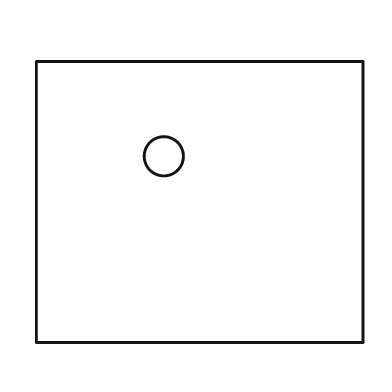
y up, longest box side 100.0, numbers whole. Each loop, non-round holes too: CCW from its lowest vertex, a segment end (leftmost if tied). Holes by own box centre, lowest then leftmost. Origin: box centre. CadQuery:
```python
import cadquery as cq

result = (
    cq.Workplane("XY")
    .moveTo(-50.0, -43.0)
    .lineTo(50.0, -43.0)
    .lineTo(50.0, 43.0)
    .lineTo(-50.0, 43.0)
    .close()
    .moveTo(-11.0, 14.0)
    .circle(6.0)
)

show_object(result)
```